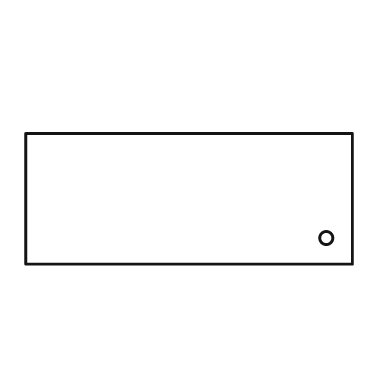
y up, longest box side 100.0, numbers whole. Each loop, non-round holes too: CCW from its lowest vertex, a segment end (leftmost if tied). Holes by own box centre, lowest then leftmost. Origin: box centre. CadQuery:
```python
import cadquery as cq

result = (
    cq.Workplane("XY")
    .moveTo(-50.0, -20.0)
    .lineTo(50.0, -20.0)
    .lineTo(50.0, 20.0)
    .lineTo(-50.0, 20.0)
    .close()
    .moveTo(42.0, -12.0)
    .circle(2.0)
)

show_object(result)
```